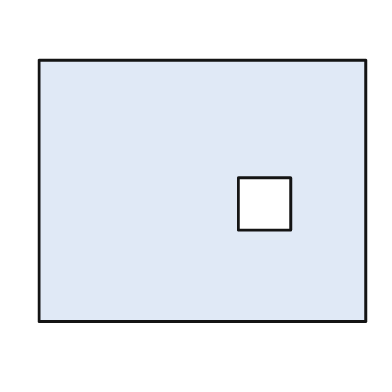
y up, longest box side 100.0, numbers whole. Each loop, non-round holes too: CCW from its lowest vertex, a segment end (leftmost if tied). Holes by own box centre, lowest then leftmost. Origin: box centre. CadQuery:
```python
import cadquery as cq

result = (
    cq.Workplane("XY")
    .moveTo(-50.0, -40.0)
    .lineTo(50.0, -40.0)
    .lineTo(50.0, 40.0)
    .lineTo(-50.0, 40.0)
    .close()
    .moveTo(11.0, -12.0)
    .lineTo(27.0, -12.0)
    .lineTo(27.0, 4.0)
    .lineTo(11.0, 4.0)
    .close()
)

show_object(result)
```